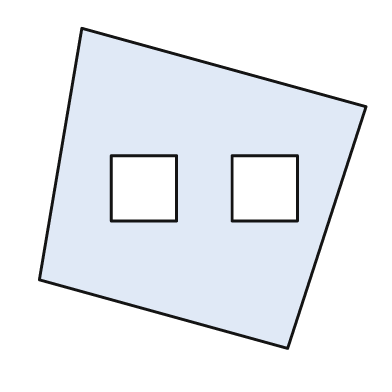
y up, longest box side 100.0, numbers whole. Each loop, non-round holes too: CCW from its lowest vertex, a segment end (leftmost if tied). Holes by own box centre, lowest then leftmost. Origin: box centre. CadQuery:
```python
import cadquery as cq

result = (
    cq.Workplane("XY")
    .moveTo(26.0, -49.0)
    .lineTo(50.0, 25.0)
    .lineTo(-37.0, 49.0)
    .lineTo(-50.0, -28.0)
    .close()
    .moveTo(-28.0, -10.0)
    .lineTo(-8.0, -10.0)
    .lineTo(-8.0, 10.0)
    .lineTo(-28.0, 10.0)
    .close()
    .moveTo(9.0, -10.0)
    .lineTo(29.0, -10.0)
    .lineTo(29.0, 10.0)
    .lineTo(9.0, 10.0)
    .close()
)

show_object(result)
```